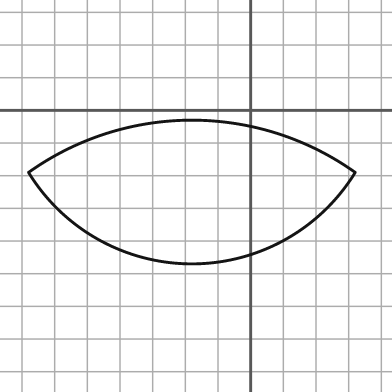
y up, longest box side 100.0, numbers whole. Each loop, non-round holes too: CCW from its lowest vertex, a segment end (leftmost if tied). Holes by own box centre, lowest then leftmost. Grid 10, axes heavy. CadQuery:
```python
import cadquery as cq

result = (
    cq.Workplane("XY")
    .moveTo(-68.0, -19.0)
    .threePointArc((-18.0, -47.0), (32.0, -19.0))
    .threePointArc((-18.0, -3.0), (-68.0, -19.0))
    .close()
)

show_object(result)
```